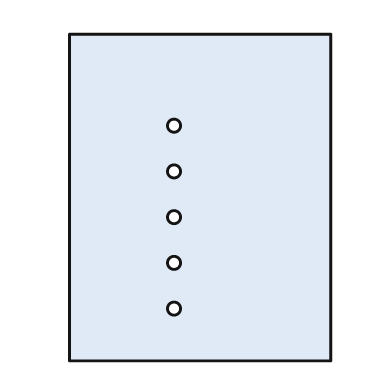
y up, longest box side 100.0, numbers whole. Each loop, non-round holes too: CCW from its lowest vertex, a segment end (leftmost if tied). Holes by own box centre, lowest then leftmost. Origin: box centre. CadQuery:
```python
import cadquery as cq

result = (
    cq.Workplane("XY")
    .moveTo(-40.0, -50.0)
    .lineTo(40.0, -50.0)
    .lineTo(40.0, 50.0)
    .lineTo(-40.0, 50.0)
    .close()
    .moveTo(-8.0, -34.0)
    .circle(2.0)
    .moveTo(-8.0, -20.0)
    .circle(2.0)
    .moveTo(-8.0, -6.0)
    .circle(2.0)
    .moveTo(-8.0, 8.0)
    .circle(2.0)
    .moveTo(-8.0, 22.0)
    .circle(2.0)
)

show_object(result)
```